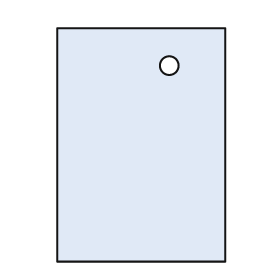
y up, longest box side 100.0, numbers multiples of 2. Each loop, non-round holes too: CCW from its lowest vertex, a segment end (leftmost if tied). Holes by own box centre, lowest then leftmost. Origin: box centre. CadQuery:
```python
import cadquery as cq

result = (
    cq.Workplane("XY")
    .moveTo(-36.0, -50.0)
    .lineTo(36.0, -50.0)
    .lineTo(36.0, 50.0)
    .lineTo(-36.0, 50.0)
    .close()
    .moveTo(12.0, 34.0)
    .circle(4.0)
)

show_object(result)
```